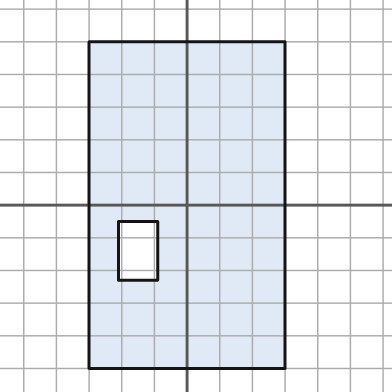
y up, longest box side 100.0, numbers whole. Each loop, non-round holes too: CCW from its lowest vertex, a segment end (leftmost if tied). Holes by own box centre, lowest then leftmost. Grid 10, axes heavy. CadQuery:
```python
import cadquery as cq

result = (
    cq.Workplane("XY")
    .moveTo(-30.0, -50.0)
    .lineTo(30.0, -50.0)
    .lineTo(30.0, 50.0)
    .lineTo(-30.0, 50.0)
    .close()
    .moveTo(-21.0, -23.0)
    .lineTo(-9.0, -23.0)
    .lineTo(-9.0, -5.0)
    .lineTo(-21.0, -5.0)
    .close()
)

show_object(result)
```